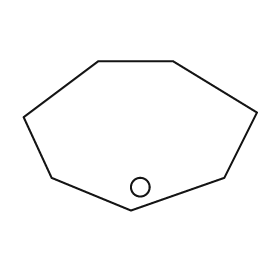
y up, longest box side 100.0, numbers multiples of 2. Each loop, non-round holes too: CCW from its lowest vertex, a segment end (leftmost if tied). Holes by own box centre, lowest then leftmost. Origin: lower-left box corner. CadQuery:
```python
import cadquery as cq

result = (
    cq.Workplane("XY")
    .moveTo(46.0, 0.0)
    .lineTo(86.0, 14.0)
    .lineTo(100.0, 42.0)
    .lineTo(64.0, 64.0)
    .lineTo(32.0, 64.0)
    .lineTo(0.0, 40.0)
    .lineTo(12.0, 14.0)
    .close()
    .moveTo(50.0, 10.0)
    .circle(4.0)
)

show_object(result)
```